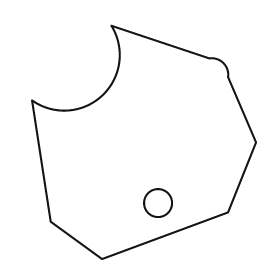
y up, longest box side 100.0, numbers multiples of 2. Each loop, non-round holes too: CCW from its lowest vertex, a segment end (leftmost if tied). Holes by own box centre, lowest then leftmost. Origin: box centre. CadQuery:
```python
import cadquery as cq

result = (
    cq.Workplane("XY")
    .moveTo(-18.0, -50.0)
    .lineTo(36.0, -30.0)
    .lineTo(48.0, 0.0)
    .lineTo(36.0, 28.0)
    .threePointArc((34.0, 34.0), (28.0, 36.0))
    .lineTo(-14.0, 50.0)
    .threePointArc((-18.0, 20.0), (-48.0, 18.0))
    .lineTo(-40.0, -34.0)
    .close()
    .moveTo(6.0, -26.0)
    .circle(6.0)
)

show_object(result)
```